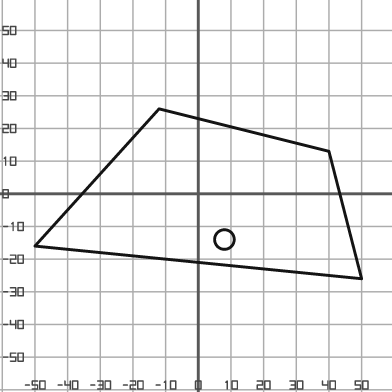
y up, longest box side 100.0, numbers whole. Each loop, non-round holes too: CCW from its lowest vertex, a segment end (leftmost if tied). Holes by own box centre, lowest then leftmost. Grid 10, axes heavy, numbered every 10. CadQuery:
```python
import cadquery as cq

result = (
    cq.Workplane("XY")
    .moveTo(50.0, -26.0)
    .lineTo(40.0, 13.0)
    .lineTo(-12.0, 26.0)
    .lineTo(-50.0, -16.0)
    .close()
    .moveTo(8.0, -14.0)
    .circle(3.0)
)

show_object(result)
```